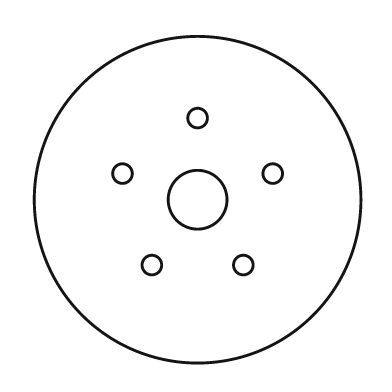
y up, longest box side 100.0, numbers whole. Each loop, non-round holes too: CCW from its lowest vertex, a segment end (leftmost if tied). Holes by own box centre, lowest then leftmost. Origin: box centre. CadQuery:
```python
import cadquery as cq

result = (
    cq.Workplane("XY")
    .moveTo(0.0, 0.0)
    .circle(50.0)
    .moveTo(-14.0, -20.0)
    .circle(3.0)
    .moveTo(14.0, -20.0)
    .circle(3.0)
    .moveTo(0.0, 0.0)
    .circle(9.0)
    .moveTo(-23.0, 8.0)
    .circle(3.0)
    .moveTo(23.0, 8.0)
    .circle(3.0)
    .moveTo(0.0, 25.0)
    .circle(3.0)
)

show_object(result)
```